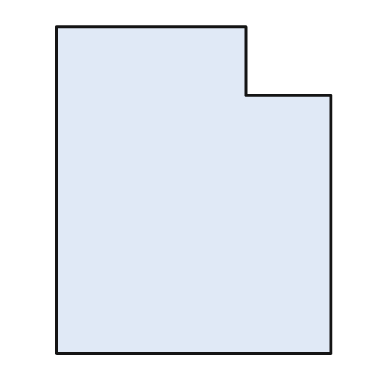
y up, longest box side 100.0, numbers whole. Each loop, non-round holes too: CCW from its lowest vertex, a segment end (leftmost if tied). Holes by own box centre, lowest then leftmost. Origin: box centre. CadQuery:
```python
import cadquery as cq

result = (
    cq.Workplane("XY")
    .moveTo(-42.0, -50.0)
    .lineTo(42.0, -50.0)
    .lineTo(42.0, 29.0)
    .lineTo(16.0, 29.0)
    .lineTo(16.0, 50.0)
    .lineTo(-42.0, 50.0)
    .close()
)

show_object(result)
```